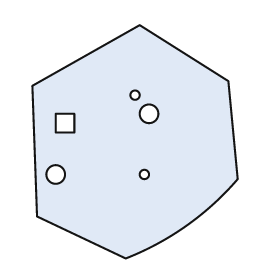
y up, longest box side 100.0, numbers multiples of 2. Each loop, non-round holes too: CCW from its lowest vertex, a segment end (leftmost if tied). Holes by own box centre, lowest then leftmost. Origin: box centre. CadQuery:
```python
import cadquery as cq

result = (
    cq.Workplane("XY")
    .moveTo(-4.0, -50.0)
    .threePointArc((22.0, -36.0), (44.0, -16.0))
    .lineTo(40.0, 26.0)
    .lineTo(2.0, 50.0)
    .lineTo(-44.0, 24.0)
    .lineTo(-42.0, -32.0)
    .close()
    .moveTo(-34.0, -14.0)
    .circle(4.0)
    .moveTo(4.0, -14.0)
    .circle(2.0)
    .moveTo(-34.0, 4.0)
    .lineTo(-26.0, 4.0)
    .lineTo(-26.0, 12.0)
    .lineTo(-34.0, 12.0)
    .close()
    .moveTo(6.0, 12.0)
    .circle(4.0)
    .moveTo(0.0, 20.0)
    .circle(2.0)
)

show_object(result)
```